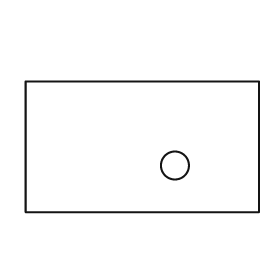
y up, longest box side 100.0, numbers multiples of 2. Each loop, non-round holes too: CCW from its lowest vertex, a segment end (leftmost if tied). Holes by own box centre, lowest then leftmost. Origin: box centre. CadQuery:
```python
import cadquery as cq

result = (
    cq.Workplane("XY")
    .moveTo(-50.0, -28.0)
    .lineTo(50.0, -28.0)
    .lineTo(50.0, 28.0)
    .lineTo(-50.0, 28.0)
    .close()
    .moveTo(14.0, -8.0)
    .circle(6.0)
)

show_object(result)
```